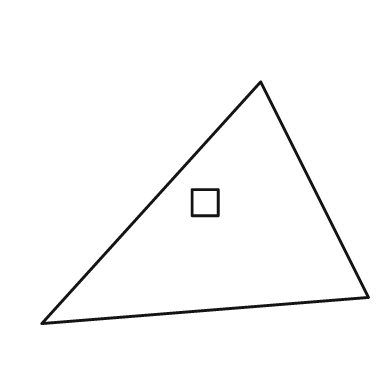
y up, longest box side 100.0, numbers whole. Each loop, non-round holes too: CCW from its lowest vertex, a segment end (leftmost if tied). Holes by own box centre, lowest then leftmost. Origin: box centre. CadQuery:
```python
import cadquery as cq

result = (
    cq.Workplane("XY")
    .moveTo(-50.0, -37.0)
    .lineTo(50.0, -29.0)
    .lineTo(17.0, 37.0)
    .close()
    .moveTo(-4.0, -4.0)
    .lineTo(4.0, -4.0)
    .lineTo(4.0, 4.0)
    .lineTo(-4.0, 4.0)
    .close()
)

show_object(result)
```